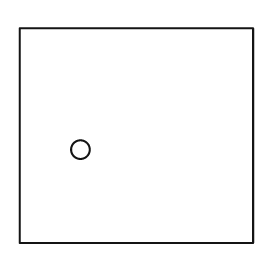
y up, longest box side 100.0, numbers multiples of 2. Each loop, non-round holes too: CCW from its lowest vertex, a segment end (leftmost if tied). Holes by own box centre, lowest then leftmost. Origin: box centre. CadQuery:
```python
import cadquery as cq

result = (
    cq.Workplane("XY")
    .moveTo(-50.0, -46.0)
    .lineTo(50.0, -46.0)
    .lineTo(50.0, 46.0)
    .lineTo(-50.0, 46.0)
    .close()
    .moveTo(-24.0, -6.0)
    .circle(4.0)
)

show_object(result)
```